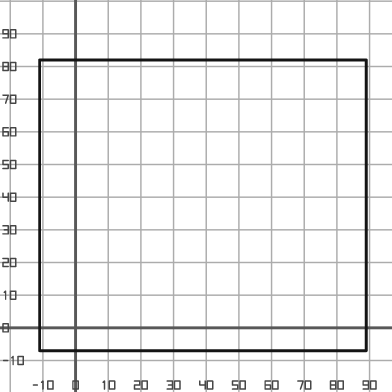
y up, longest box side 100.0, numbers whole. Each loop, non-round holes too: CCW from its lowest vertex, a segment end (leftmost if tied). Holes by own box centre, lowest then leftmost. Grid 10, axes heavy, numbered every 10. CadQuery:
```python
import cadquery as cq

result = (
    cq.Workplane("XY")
    .moveTo(-11.0, -7.0)
    .lineTo(89.0, -7.0)
    .lineTo(89.0, 82.0)
    .lineTo(-11.0, 82.0)
    .close()
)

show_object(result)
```